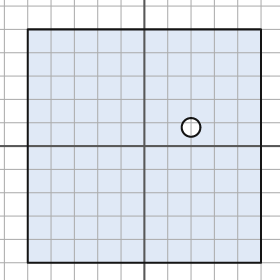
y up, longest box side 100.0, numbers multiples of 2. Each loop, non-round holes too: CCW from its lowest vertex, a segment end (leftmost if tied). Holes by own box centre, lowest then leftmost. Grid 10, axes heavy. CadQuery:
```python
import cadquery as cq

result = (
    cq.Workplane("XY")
    .moveTo(-50.0, -50.0)
    .lineTo(50.0, -50.0)
    .lineTo(50.0, 50.0)
    .lineTo(-50.0, 50.0)
    .close()
    .moveTo(20.0, 8.0)
    .circle(4.0)
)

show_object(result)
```